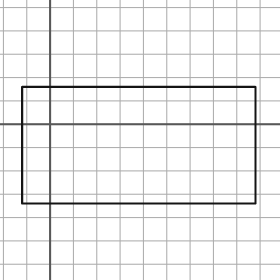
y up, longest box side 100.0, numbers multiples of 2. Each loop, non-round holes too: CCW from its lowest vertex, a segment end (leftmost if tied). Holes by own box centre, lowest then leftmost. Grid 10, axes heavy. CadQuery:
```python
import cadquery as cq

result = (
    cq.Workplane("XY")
    .moveTo(-12.0, -34.0)
    .lineTo(88.0, -34.0)
    .lineTo(88.0, 16.0)
    .lineTo(-12.0, 16.0)
    .close()
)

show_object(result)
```